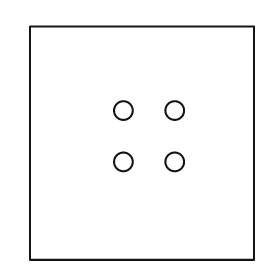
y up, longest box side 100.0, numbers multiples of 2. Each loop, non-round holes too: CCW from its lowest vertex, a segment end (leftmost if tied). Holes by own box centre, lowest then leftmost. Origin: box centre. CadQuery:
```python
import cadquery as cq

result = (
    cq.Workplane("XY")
    .moveTo(-48.0, -50.0)
    .lineTo(48.0, -50.0)
    .lineTo(48.0, 50.0)
    .lineTo(-48.0, 50.0)
    .close()
    .moveTo(-8.0, -8.0)
    .circle(4.0)
    .moveTo(14.0, -8.0)
    .circle(4.0)
    .moveTo(-8.0, 14.0)
    .circle(4.0)
    .moveTo(14.0, 14.0)
    .circle(4.0)
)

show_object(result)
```